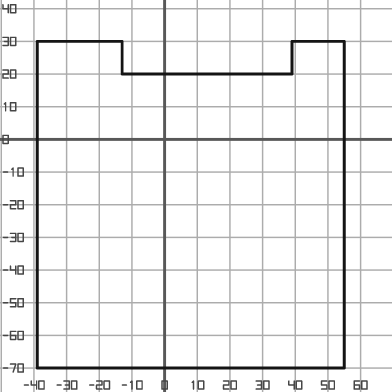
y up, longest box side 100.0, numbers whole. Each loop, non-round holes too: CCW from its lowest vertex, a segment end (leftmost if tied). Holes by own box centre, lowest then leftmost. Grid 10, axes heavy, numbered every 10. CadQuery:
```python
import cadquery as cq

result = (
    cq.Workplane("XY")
    .moveTo(-39.0, -70.0)
    .lineTo(55.0, -70.0)
    .lineTo(55.0, 30.0)
    .lineTo(39.0, 30.0)
    .lineTo(39.0, 20.0)
    .lineTo(-13.0, 20.0)
    .lineTo(-13.0, 30.0)
    .lineTo(-39.0, 30.0)
    .close()
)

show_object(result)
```